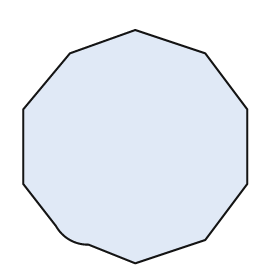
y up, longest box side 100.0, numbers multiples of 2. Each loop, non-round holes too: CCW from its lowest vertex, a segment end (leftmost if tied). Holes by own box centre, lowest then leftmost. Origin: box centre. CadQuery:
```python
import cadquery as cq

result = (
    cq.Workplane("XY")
    .moveTo(0.0, -50.0)
    .lineTo(30.0, -40.0)
    .lineTo(48.0, -16.0)
    .lineTo(48.0, 16.0)
    .lineTo(30.0, 40.0)
    .lineTo(0.0, 50.0)
    .lineTo(-28.0, 40.0)
    .lineTo(-48.0, 16.0)
    .lineTo(-48.0, -16.0)
    .lineTo(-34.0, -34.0)
    .threePointArc((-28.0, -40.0), (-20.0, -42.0))
    .close()
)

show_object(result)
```